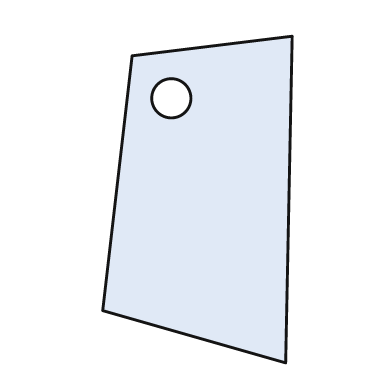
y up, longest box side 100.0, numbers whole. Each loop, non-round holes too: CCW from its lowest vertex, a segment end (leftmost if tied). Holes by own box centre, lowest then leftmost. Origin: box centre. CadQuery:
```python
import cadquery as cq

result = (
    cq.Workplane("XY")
    .moveTo(27.0, -50.0)
    .lineTo(29.0, 50.0)
    .lineTo(-20.0, 44.0)
    .lineTo(-29.0, -34.0)
    .close()
    .moveTo(-8.0, 31.0)
    .circle(6.0)
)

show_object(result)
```